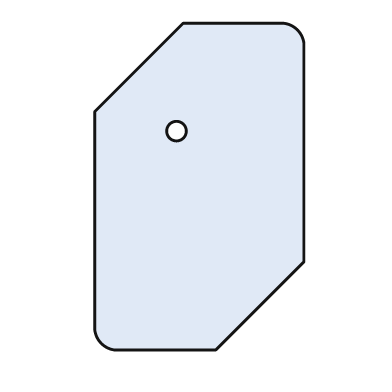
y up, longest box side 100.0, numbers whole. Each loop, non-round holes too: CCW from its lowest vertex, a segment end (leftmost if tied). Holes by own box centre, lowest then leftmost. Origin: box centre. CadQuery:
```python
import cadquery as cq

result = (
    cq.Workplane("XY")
    .moveTo(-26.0, -50.0)
    .lineTo(5.0, -50.0)
    .lineTo(32.0, -23.0)
    .lineTo(32.0, 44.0)
    .threePointArc((30.0, 48.0), (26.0, 50.0))
    .lineTo(-5.0, 50.0)
    .lineTo(-32.0, 23.0)
    .lineTo(-32.0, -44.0)
    .threePointArc((-30.0, -48.0), (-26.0, -50.0))
    .close()
    .moveTo(-7.0, 17.0)
    .circle(3.0)
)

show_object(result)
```